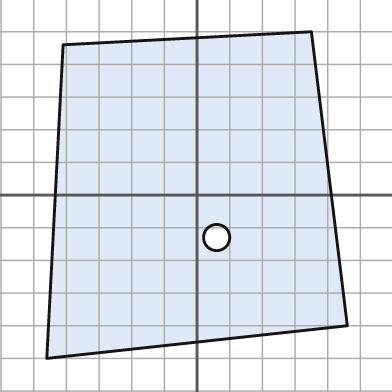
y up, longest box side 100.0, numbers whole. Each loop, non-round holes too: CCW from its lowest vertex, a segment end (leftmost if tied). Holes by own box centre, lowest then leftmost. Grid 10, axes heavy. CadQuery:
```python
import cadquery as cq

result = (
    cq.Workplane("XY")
    .moveTo(-46.0, -50.0)
    .lineTo(46.0, -40.0)
    .lineTo(35.0, 50.0)
    .lineTo(-41.0, 46.0)
    .close()
    .moveTo(6.0, -13.0)
    .circle(4.0)
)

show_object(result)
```